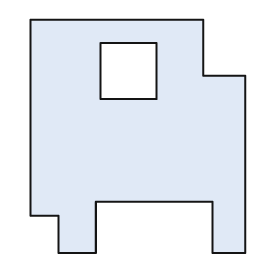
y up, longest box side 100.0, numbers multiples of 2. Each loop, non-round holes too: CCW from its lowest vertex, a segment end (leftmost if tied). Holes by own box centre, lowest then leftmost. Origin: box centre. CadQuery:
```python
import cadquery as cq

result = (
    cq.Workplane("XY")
    .moveTo(-34.0, -50.0)
    .lineTo(-18.0, -50.0)
    .lineTo(-18.0, -28.0)
    .lineTo(32.0, -28.0)
    .lineTo(32.0, -50.0)
    .lineTo(46.0, -50.0)
    .lineTo(46.0, 26.0)
    .lineTo(28.0, 26.0)
    .lineTo(28.0, 50.0)
    .lineTo(-46.0, 50.0)
    .lineTo(-46.0, -34.0)
    .lineTo(-34.0, -34.0)
    .close()
    .moveTo(-16.0, 16.0)
    .lineTo(8.0, 16.0)
    .lineTo(8.0, 40.0)
    .lineTo(-16.0, 40.0)
    .close()
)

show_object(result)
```